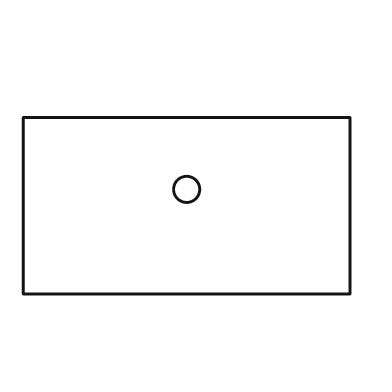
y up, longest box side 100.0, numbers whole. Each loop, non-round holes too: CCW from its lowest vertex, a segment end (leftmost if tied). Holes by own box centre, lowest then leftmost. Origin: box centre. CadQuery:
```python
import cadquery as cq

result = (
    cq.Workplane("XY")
    .moveTo(-50.0, -27.0)
    .lineTo(50.0, -27.0)
    .lineTo(50.0, 27.0)
    .lineTo(-50.0, 27.0)
    .close()
    .moveTo(0.0, 5.0)
    .circle(4.0)
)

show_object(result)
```